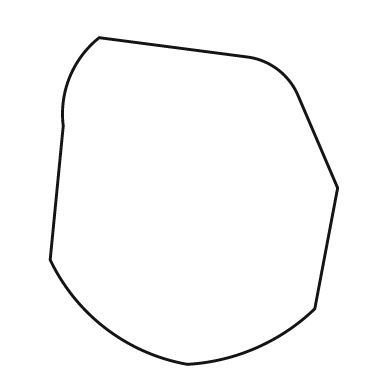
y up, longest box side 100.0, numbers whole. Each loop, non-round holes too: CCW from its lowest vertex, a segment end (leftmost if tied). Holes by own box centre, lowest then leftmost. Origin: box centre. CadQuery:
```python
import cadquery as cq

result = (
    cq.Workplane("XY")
    .moveTo(-2.0, -50.0)
    .threePointArc((19.0, -45.0), (37.0, -33.0))
    .lineTo(44.0, 4.0)
    .lineTo(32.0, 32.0)
    .threePointArc((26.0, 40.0), (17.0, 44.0))
    .lineTo(-29.0, 50.0)
    .threePointArc((-38.0, 38.0), (-40.0, 23.0))
    .lineTo(-44.0, -18.0)
    .threePointArc((-27.0, -39.0), (-2.0, -50.0))
    .close()
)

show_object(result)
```